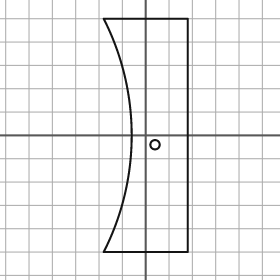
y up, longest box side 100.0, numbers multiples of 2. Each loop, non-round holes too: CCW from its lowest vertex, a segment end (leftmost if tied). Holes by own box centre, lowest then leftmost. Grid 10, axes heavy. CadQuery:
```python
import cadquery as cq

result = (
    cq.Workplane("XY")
    .moveTo(-18.0, -50.0)
    .lineTo(18.0, -50.0)
    .lineTo(18.0, 50.0)
    .lineTo(-18.0, 50.0)
    .threePointArc((-6.0, 0.0), (-18.0, -50.0))
    .close()
    .moveTo(4.0, -4.0)
    .circle(2.0)
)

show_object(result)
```